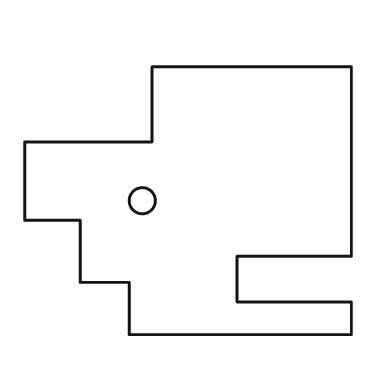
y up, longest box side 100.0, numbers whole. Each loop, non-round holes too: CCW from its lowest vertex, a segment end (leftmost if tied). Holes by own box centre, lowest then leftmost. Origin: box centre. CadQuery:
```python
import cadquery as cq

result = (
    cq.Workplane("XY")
    .moveTo(-18.0, -41.0)
    .lineTo(50.0, -41.0)
    .lineTo(50.0, -31.0)
    .lineTo(15.0, -31.0)
    .lineTo(15.0, -17.0)
    .lineTo(50.0, -17.0)
    .lineTo(50.0, 41.0)
    .lineTo(-11.0, 41.0)
    .lineTo(-11.0, 18.0)
    .lineTo(-50.0, 18.0)
    .lineTo(-50.0, -6.0)
    .lineTo(-33.0, -6.0)
    .lineTo(-33.0, -25.0)
    .lineTo(-18.0, -25.0)
    .close()
    .moveTo(-14.0, 0.0)
    .circle(4.0)
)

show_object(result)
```